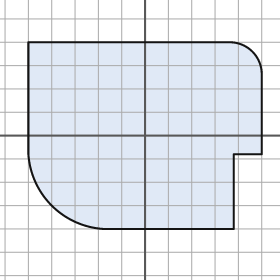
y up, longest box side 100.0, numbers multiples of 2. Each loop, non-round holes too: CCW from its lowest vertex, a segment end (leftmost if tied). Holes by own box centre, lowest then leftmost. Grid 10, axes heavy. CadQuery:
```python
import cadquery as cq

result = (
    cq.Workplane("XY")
    .moveTo(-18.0, -40.0)
    .lineTo(38.0, -40.0)
    .lineTo(38.0, -8.0)
    .lineTo(50.0, -8.0)
    .lineTo(50.0, 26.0)
    .threePointArc((46.0, 36.0), (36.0, 40.0))
    .lineTo(-50.0, 40.0)
    .lineTo(-50.0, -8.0)
    .threePointArc((-40.0, -30.0), (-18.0, -40.0))
    .close()
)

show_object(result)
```